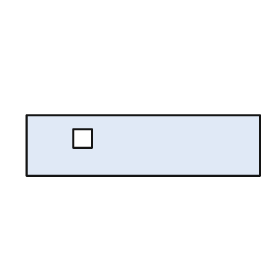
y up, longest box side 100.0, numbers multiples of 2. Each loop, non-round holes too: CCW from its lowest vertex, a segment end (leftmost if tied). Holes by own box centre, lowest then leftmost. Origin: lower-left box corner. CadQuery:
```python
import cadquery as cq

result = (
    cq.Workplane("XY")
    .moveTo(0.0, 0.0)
    .lineTo(100.0, 0.0)
    .lineTo(100.0, 26.0)
    .lineTo(0.0, 26.0)
    .close()
    .moveTo(20.0, 12.0)
    .lineTo(28.0, 12.0)
    .lineTo(28.0, 20.0)
    .lineTo(20.0, 20.0)
    .close()
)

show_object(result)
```